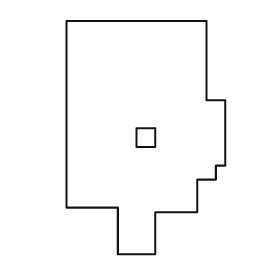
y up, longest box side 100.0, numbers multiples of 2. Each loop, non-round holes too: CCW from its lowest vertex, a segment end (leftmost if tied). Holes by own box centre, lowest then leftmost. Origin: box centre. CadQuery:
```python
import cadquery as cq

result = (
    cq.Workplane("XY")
    .moveTo(-12.0, -50.0)
    .lineTo(4.0, -50.0)
    .lineTo(4.0, -32.0)
    .lineTo(22.0, -32.0)
    .lineTo(22.0, -18.0)
    .lineTo(30.0, -18.0)
    .lineTo(30.0, -12.0)
    .lineTo(34.0, -12.0)
    .lineTo(34.0, 16.0)
    .lineTo(26.0, 16.0)
    .lineTo(26.0, 50.0)
    .lineTo(-34.0, 50.0)
    .lineTo(-34.0, -30.0)
    .lineTo(-12.0, -30.0)
    .close()
    .moveTo(-4.0, -4.0)
    .lineTo(4.0, -4.0)
    .lineTo(4.0, 4.0)
    .lineTo(-4.0, 4.0)
    .close()
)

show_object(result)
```